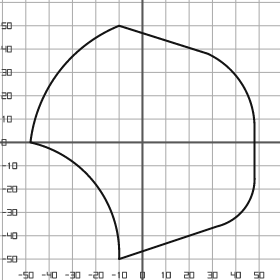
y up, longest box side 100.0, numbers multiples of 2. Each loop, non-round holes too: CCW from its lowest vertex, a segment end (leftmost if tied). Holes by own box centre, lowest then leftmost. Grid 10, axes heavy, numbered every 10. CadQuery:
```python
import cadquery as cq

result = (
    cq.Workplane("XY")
    .moveTo(-10.0, -50.0)
    .lineTo(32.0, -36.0)
    .threePointArc((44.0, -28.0), (48.0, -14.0))
    .lineTo(48.0, 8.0)
    .threePointArc((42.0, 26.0), (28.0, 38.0))
    .lineTo(-10.0, 50.0)
    .threePointArc((-36.0, 30.0), (-48.0, 0.0))
    .threePointArc((-20.0, -18.0), (-10.0, -50.0))
    .close()
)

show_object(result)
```